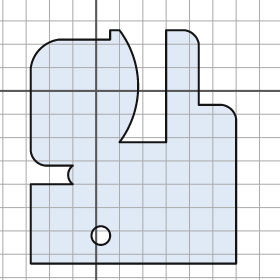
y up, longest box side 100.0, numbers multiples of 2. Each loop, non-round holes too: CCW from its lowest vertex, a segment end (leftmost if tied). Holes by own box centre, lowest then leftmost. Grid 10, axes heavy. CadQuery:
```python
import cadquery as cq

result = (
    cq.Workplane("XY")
    .moveTo(-28.0, -74.0)
    .lineTo(60.0, -74.0)
    .lineTo(60.0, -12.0)
    .threePointArc((58.0, -8.0), (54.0, -6.0))
    .lineTo(44.0, -6.0)
    .lineTo(44.0, 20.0)
    .threePointArc((42.0, 24.0), (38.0, 26.0))
    .lineTo(30.0, 26.0)
    .lineTo(30.0, -22.0)
    .lineTo(10.0, -22.0)
    .threePointArc((18.0, 2.0), (10.0, 26.0))
    .lineTo(6.0, 26.0)
    .lineTo(6.0, 22.0)
    .lineTo(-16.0, 22.0)
    .threePointArc((-24.0, 18.0), (-28.0, 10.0))
    .lineTo(-28.0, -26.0)
    .threePointArc((-26.0, -30.0), (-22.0, -32.0))
    .lineTo(-10.0, -32.0)
    .threePointArc((-12.0, -36.0), (-10.0, -40.0))
    .lineTo(-28.0, -40.0)
    .close()
    .moveTo(2.0, -62.0)
    .circle(4.0)
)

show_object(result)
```